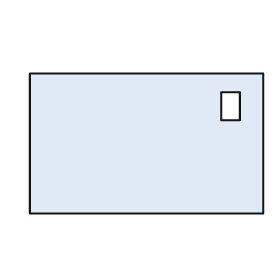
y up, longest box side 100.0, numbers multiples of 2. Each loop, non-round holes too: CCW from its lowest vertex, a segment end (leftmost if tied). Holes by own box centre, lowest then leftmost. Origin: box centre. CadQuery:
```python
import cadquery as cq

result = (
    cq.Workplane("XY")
    .moveTo(-50.0, -30.0)
    .lineTo(50.0, -30.0)
    .lineTo(50.0, 30.0)
    .lineTo(-50.0, 30.0)
    .close()
    .moveTo(32.0, 10.0)
    .lineTo(40.0, 10.0)
    .lineTo(40.0, 22.0)
    .lineTo(32.0, 22.0)
    .close()
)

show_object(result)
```